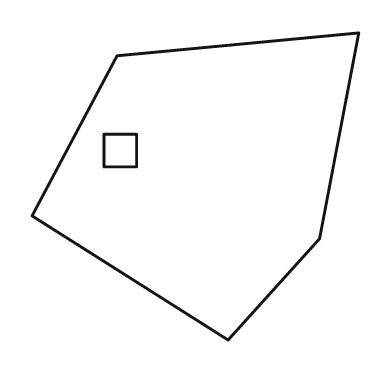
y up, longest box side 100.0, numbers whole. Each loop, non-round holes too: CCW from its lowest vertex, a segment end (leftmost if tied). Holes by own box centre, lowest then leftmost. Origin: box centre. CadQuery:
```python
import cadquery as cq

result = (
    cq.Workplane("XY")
    .moveTo(10.0, -47.0)
    .lineTo(38.0, -16.0)
    .lineTo(50.0, 47.0)
    .lineTo(-24.0, 40.0)
    .lineTo(-50.0, -9.0)
    .close()
    .moveTo(-28.0, 6.0)
    .lineTo(-18.0, 6.0)
    .lineTo(-18.0, 16.0)
    .lineTo(-28.0, 16.0)
    .close()
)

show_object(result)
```